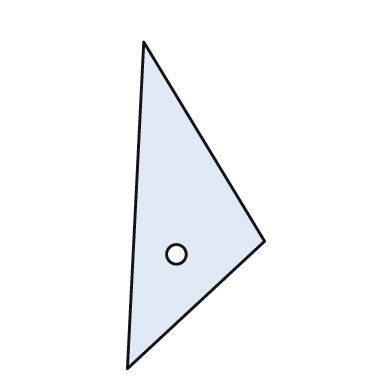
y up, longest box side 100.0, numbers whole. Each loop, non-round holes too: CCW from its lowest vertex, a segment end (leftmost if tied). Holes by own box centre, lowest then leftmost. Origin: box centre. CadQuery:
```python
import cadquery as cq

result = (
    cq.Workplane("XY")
    .moveTo(-21.0, -50.0)
    .lineTo(21.0, -11.0)
    .lineTo(-16.0, 50.0)
    .close()
    .moveTo(-6.0, -15.0)
    .circle(3.0)
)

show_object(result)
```